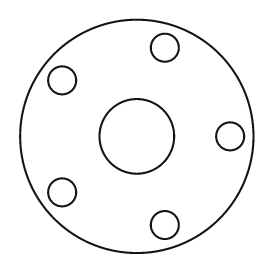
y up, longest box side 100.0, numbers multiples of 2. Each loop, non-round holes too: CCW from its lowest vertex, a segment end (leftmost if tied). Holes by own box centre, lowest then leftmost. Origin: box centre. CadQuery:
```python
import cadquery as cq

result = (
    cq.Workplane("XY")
    .moveTo(0.0, 0.0)
    .circle(50.0)
    .moveTo(12.0, -38.0)
    .circle(6.0)
    .moveTo(-32.0, -24.0)
    .circle(6.0)
    .moveTo(0.0, 0.0)
    .circle(16.0)
    .moveTo(40.0, 0.0)
    .circle(6.0)
    .moveTo(-32.0, 24.0)
    .circle(6.0)
    .moveTo(12.0, 38.0)
    .circle(6.0)
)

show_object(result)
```